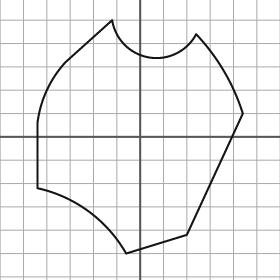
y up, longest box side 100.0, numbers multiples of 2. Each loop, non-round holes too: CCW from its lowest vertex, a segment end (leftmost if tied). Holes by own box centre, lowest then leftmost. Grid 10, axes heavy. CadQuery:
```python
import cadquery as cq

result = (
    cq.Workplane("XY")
    .moveTo(-6.0, -50.0)
    .lineTo(20.0, -42.0)
    .lineTo(44.0, 10.0)
    .threePointArc((36.0, 28.0), (24.0, 44.0))
    .threePointArc((4.0, 34.0), (-12.0, 50.0))
    .lineTo(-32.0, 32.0)
    .threePointArc((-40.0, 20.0), (-44.0, 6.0))
    .lineTo(-44.0, -22.0)
    .threePointArc((-22.0, -32.0), (-6.0, -50.0))
    .close()
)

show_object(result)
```